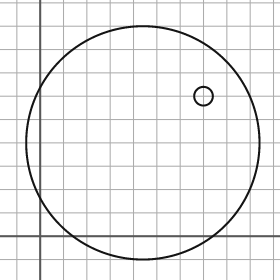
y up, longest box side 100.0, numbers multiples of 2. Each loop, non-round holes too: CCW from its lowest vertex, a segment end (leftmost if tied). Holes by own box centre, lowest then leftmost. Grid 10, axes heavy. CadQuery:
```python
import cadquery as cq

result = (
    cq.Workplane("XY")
    .moveTo(44.0, 40.0)
    .circle(50.0)
    .moveTo(70.0, 60.0)
    .circle(4.0)
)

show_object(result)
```